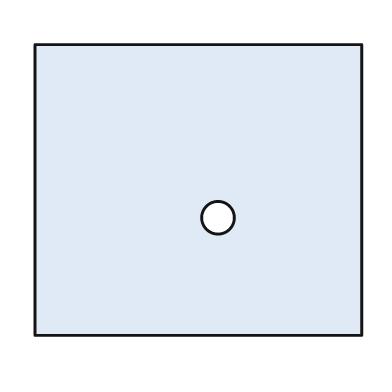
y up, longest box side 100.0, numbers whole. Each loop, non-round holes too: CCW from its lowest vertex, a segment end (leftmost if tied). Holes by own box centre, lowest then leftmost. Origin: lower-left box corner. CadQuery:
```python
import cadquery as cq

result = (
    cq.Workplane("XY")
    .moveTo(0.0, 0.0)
    .lineTo(100.0, 0.0)
    .lineTo(100.0, 89.0)
    .lineTo(0.0, 89.0)
    .close()
    .moveTo(56.0, 36.0)
    .circle(5.0)
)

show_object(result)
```